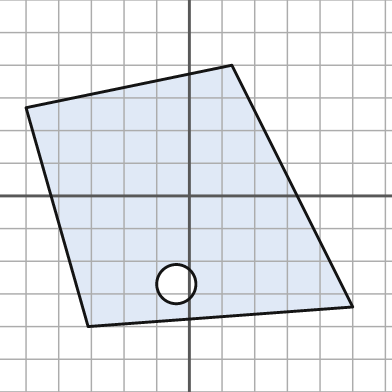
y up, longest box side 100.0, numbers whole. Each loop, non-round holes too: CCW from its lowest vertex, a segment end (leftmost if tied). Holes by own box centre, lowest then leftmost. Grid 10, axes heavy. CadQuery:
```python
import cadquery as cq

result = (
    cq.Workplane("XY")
    .moveTo(-31.0, -40.0)
    .lineTo(50.0, -34.0)
    .lineTo(13.0, 40.0)
    .lineTo(-50.0, 27.0)
    .close()
    .moveTo(-4.0, -27.0)
    .circle(6.0)
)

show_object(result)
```